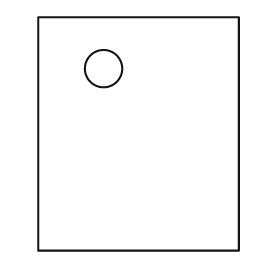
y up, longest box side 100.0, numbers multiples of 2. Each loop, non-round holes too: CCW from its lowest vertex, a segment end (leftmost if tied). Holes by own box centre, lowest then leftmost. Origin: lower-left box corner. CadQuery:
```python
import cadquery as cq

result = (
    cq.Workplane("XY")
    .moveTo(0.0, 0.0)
    .lineTo(86.0, 0.0)
    .lineTo(86.0, 100.0)
    .lineTo(0.0, 100.0)
    .close()
    .moveTo(28.0, 78.0)
    .circle(8.0)
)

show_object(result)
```